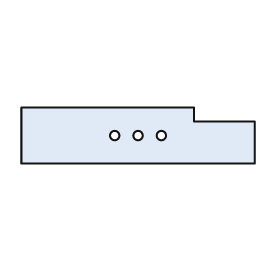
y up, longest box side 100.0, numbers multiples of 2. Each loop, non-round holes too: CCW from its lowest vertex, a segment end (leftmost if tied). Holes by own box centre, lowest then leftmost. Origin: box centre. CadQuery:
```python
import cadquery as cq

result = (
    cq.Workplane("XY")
    .moveTo(-50.0, -12.0)
    .lineTo(50.0, -12.0)
    .lineTo(50.0, 6.0)
    .lineTo(24.0, 6.0)
    .lineTo(24.0, 12.0)
    .lineTo(-50.0, 12.0)
    .close()
    .moveTo(-10.0, 0.0)
    .circle(2.0)
    .moveTo(0.0, 0.0)
    .circle(2.0)
    .moveTo(10.0, 0.0)
    .circle(2.0)
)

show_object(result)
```